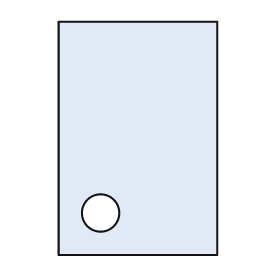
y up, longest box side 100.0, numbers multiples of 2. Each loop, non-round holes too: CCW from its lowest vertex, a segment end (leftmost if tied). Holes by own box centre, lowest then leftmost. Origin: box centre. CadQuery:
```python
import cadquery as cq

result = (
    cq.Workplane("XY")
    .moveTo(-34.0, -50.0)
    .lineTo(34.0, -50.0)
    .lineTo(34.0, 50.0)
    .lineTo(-34.0, 50.0)
    .close()
    .moveTo(-16.0, -32.0)
    .circle(8.0)
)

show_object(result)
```